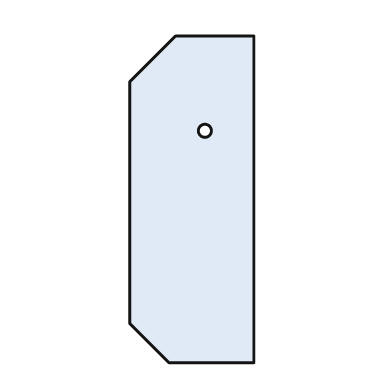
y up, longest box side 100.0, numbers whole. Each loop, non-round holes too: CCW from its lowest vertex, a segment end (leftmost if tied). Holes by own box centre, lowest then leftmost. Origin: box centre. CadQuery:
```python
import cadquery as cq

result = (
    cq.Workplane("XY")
    .moveTo(-7.0, -50.0)
    .lineTo(19.0, -50.0)
    .lineTo(19.0, 50.0)
    .lineTo(-5.0, 50.0)
    .lineTo(-19.0, 36.0)
    .lineTo(-19.0, -38.0)
    .close()
    .moveTo(4.0, 21.0)
    .circle(2.0)
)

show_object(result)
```